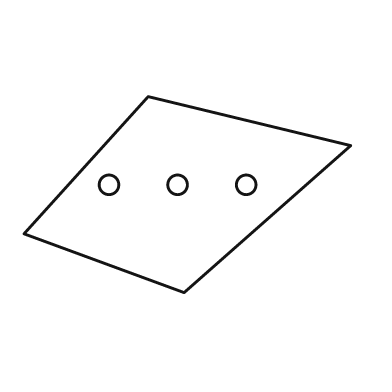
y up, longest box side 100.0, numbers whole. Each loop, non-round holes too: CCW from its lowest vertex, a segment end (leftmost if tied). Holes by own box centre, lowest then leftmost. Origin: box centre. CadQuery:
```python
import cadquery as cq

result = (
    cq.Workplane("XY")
    .moveTo(-1.0, -30.0)
    .lineTo(50.0, 15.0)
    .lineTo(-12.0, 30.0)
    .lineTo(-50.0, -12.0)
    .close()
    .moveTo(-24.0, 3.0)
    .circle(3.0)
    .moveTo(-3.0, 3.0)
    .circle(3.0)
    .moveTo(18.0, 3.0)
    .circle(3.0)
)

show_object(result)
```